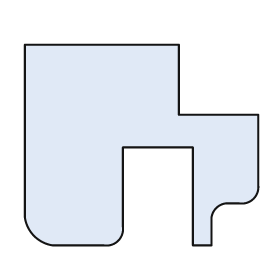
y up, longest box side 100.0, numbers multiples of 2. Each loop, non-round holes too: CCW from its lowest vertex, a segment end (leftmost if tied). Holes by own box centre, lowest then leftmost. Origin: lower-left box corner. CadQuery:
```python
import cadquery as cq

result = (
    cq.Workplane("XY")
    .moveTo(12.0, 0.0)
    .lineTo(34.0, 0.0)
    .threePointArc((40.0, 2.0), (42.0, 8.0))
    .lineTo(42.0, 42.0)
    .lineTo(72.0, 42.0)
    .lineTo(72.0, 0.0)
    .lineTo(80.0, 0.0)
    .lineTo(80.0, 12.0)
    .threePointArc((82.0, 16.0), (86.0, 18.0))
    .lineTo(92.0, 18.0)
    .threePointArc((98.0, 20.0), (100.0, 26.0))
    .lineTo(100.0, 56.0)
    .lineTo(66.0, 56.0)
    .lineTo(66.0, 86.0)
    .lineTo(0.0, 86.0)
    .lineTo(0.0, 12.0)
    .threePointArc((4.0, 4.0), (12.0, 0.0))
    .close()
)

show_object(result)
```